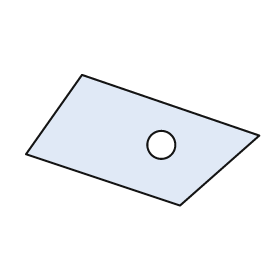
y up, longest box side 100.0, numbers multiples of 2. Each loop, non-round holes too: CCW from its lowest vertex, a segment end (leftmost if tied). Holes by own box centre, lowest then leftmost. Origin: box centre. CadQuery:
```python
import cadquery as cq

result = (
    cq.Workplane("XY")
    .moveTo(16.0, -28.0)
    .lineTo(50.0, 2.0)
    .lineTo(-26.0, 28.0)
    .lineTo(-50.0, -6.0)
    .close()
    .moveTo(8.0, -2.0)
    .circle(6.0)
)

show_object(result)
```